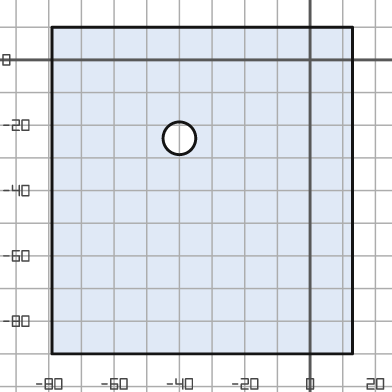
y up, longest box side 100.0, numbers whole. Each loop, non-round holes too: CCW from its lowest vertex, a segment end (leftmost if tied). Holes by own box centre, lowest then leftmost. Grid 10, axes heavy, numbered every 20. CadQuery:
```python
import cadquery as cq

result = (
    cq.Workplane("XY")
    .moveTo(-79.0, -90.0)
    .lineTo(13.0, -90.0)
    .lineTo(13.0, 10.0)
    .lineTo(-79.0, 10.0)
    .close()
    .moveTo(-40.0, -24.0)
    .circle(5.0)
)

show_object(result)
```